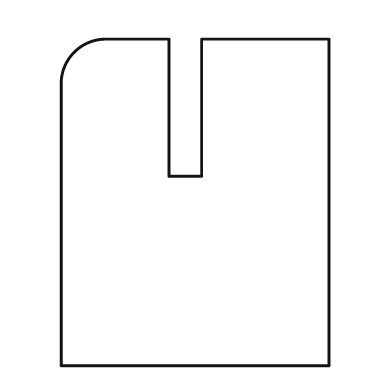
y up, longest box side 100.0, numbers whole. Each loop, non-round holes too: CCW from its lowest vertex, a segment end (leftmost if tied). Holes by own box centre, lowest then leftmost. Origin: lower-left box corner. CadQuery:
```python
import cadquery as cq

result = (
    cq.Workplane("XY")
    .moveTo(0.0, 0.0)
    .lineTo(82.0, 0.0)
    .lineTo(82.0, 100.0)
    .lineTo(43.0, 100.0)
    .lineTo(43.0, 58.0)
    .lineTo(33.0, 58.0)
    .lineTo(33.0, 100.0)
    .lineTo(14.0, 100.0)
    .threePointArc((4.0, 96.0), (0.0, 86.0))
    .close()
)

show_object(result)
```